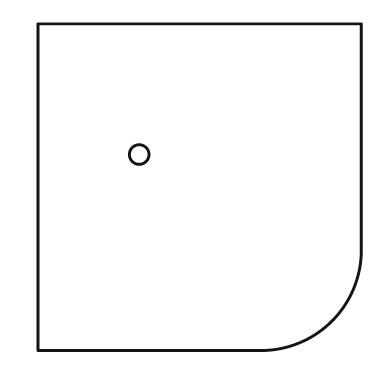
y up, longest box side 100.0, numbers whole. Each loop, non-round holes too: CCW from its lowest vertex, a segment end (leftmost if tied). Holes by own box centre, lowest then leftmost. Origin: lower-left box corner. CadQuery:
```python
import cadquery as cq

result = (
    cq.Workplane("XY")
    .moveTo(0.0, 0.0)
    .lineTo(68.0, 0.0)
    .threePointArc((90.0, 9.0), (99.0, 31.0))
    .lineTo(99.0, 100.0)
    .lineTo(0.0, 100.0)
    .close()
    .moveTo(31.0, 60.0)
    .circle(3.0)
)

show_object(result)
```